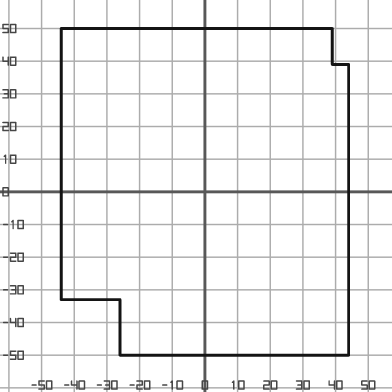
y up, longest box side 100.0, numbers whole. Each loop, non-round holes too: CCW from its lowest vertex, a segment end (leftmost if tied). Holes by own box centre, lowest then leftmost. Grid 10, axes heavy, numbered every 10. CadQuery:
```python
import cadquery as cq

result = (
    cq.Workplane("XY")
    .moveTo(-26.0, -50.0)
    .lineTo(44.0, -50.0)
    .lineTo(44.0, 39.0)
    .lineTo(39.0, 39.0)
    .lineTo(39.0, 50.0)
    .lineTo(-44.0, 50.0)
    .lineTo(-44.0, -33.0)
    .lineTo(-26.0, -33.0)
    .close()
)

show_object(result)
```